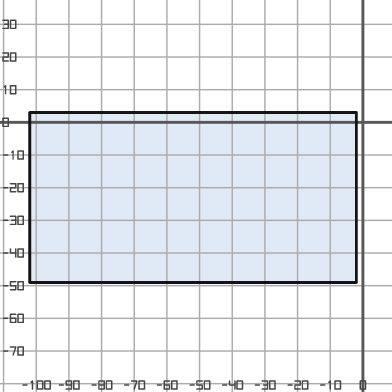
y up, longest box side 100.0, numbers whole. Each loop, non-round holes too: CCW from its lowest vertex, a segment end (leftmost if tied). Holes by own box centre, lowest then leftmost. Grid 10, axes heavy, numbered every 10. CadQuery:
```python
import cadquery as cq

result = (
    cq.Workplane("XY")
    .moveTo(-102.0, -49.0)
    .lineTo(-2.0, -49.0)
    .lineTo(-2.0, 3.0)
    .lineTo(-102.0, 3.0)
    .close()
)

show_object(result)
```